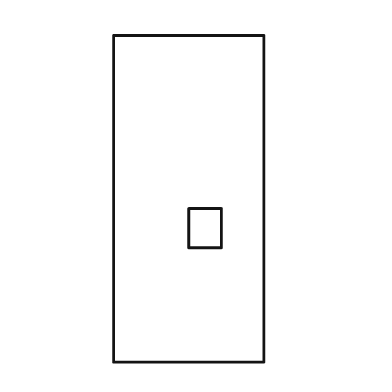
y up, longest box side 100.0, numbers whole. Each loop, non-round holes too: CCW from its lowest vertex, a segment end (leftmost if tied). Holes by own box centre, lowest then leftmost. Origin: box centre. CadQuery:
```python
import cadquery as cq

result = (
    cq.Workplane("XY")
    .moveTo(-23.0, -50.0)
    .lineTo(23.0, -50.0)
    .lineTo(23.0, 50.0)
    .lineTo(-23.0, 50.0)
    .close()
    .moveTo(0.0, -15.0)
    .lineTo(10.0, -15.0)
    .lineTo(10.0, -3.0)
    .lineTo(0.0, -3.0)
    .close()
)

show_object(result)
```